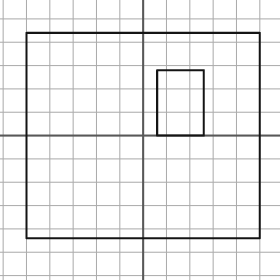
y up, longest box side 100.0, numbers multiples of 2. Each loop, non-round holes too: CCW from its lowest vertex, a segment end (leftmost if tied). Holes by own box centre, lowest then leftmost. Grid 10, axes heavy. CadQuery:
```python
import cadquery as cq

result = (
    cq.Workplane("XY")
    .moveTo(-50.0, -44.0)
    .lineTo(50.0, -44.0)
    .lineTo(50.0, 44.0)
    .lineTo(-50.0, 44.0)
    .close()
    .moveTo(6.0, 0.0)
    .lineTo(26.0, 0.0)
    .lineTo(26.0, 28.0)
    .lineTo(6.0, 28.0)
    .close()
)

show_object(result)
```